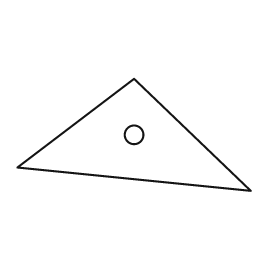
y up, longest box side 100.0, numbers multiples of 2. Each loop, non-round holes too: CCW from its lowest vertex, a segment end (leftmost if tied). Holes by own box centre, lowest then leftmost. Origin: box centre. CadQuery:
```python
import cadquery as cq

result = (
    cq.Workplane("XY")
    .moveTo(50.0, -24.0)
    .lineTo(0.0, 24.0)
    .lineTo(-50.0, -14.0)
    .close()
    .moveTo(0.0, 0.0)
    .circle(4.0)
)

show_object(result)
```